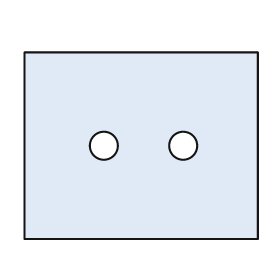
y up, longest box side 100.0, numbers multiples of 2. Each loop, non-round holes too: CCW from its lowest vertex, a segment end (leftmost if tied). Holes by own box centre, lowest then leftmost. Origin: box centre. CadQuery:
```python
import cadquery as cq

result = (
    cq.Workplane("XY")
    .moveTo(-50.0, -40.0)
    .lineTo(50.0, -40.0)
    .lineTo(50.0, 40.0)
    .lineTo(-50.0, 40.0)
    .close()
    .moveTo(-16.0, 0.0)
    .circle(6.0)
    .moveTo(18.0, 0.0)
    .circle(6.0)
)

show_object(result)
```